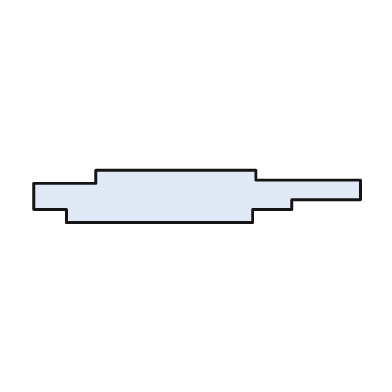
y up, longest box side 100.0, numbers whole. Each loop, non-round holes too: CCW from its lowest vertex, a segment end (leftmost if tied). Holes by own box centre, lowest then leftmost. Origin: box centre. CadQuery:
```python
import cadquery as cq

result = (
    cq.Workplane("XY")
    .moveTo(-40.0, -8.0)
    .lineTo(17.0, -8.0)
    .lineTo(17.0, -4.0)
    .lineTo(29.0, -4.0)
    .lineTo(29.0, -1.0)
    .lineTo(50.0, -1.0)
    .lineTo(50.0, 5.0)
    .lineTo(18.0, 5.0)
    .lineTo(18.0, 8.0)
    .lineTo(-31.0, 8.0)
    .lineTo(-31.0, 4.0)
    .lineTo(-50.0, 4.0)
    .lineTo(-50.0, -4.0)
    .lineTo(-40.0, -4.0)
    .close()
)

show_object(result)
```